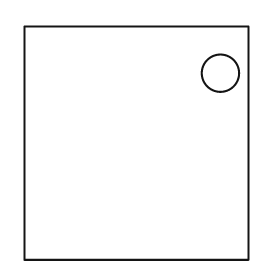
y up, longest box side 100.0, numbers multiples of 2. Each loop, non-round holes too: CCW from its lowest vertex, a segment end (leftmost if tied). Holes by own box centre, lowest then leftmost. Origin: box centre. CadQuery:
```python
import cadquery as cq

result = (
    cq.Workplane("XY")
    .moveTo(-48.0, -50.0)
    .lineTo(48.0, -50.0)
    .lineTo(48.0, 50.0)
    .lineTo(-48.0, 50.0)
    .close()
    .moveTo(36.0, 30.0)
    .circle(8.0)
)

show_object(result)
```